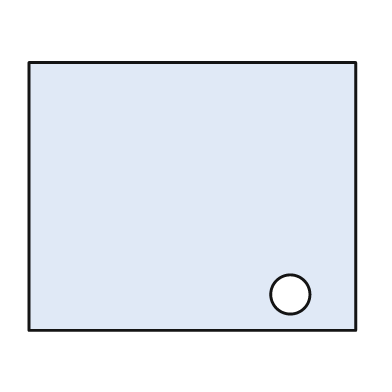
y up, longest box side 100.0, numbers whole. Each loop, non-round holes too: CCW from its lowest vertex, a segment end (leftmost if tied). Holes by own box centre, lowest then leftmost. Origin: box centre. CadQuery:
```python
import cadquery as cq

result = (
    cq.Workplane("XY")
    .moveTo(-50.0, -41.0)
    .lineTo(50.0, -41.0)
    .lineTo(50.0, 41.0)
    .lineTo(-50.0, 41.0)
    .close()
    .moveTo(30.0, -30.0)
    .circle(6.0)
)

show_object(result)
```